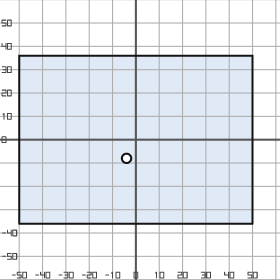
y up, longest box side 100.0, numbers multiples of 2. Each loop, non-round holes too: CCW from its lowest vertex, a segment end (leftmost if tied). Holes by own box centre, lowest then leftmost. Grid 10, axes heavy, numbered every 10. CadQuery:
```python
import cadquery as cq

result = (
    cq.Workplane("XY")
    .moveTo(-50.0, -36.0)
    .lineTo(50.0, -36.0)
    .lineTo(50.0, 36.0)
    .lineTo(-50.0, 36.0)
    .close()
    .moveTo(-4.0, -8.0)
    .circle(2.0)
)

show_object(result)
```